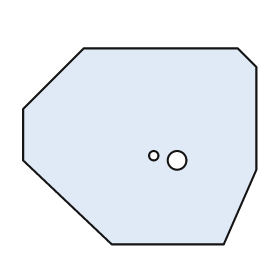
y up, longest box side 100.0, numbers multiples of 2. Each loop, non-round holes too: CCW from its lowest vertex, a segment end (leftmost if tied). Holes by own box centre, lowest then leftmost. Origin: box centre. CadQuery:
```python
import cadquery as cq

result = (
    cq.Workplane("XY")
    .moveTo(-12.0, -42.0)
    .lineTo(36.0, -42.0)
    .lineTo(50.0, -10.0)
    .lineTo(50.0, 34.0)
    .lineTo(42.0, 42.0)
    .lineTo(-24.0, 42.0)
    .lineTo(-50.0, 16.0)
    .lineTo(-50.0, -6.0)
    .close()
    .moveTo(16.0, -6.0)
    .circle(4.0)
    .moveTo(6.0, -4.0)
    .circle(2.0)
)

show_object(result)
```